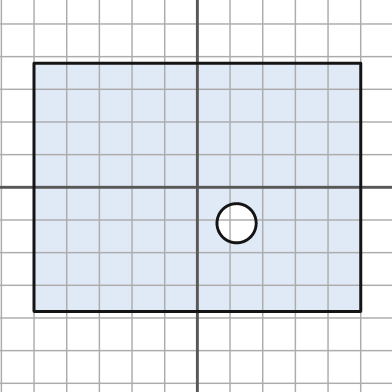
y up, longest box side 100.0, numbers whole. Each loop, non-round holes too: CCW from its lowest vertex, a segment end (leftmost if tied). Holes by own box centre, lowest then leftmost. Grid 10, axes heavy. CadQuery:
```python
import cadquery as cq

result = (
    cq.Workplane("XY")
    .moveTo(-50.0, -38.0)
    .lineTo(50.0, -38.0)
    .lineTo(50.0, 38.0)
    .lineTo(-50.0, 38.0)
    .close()
    .moveTo(12.0, -11.0)
    .circle(6.0)
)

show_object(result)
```